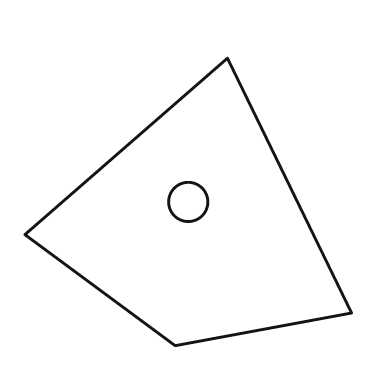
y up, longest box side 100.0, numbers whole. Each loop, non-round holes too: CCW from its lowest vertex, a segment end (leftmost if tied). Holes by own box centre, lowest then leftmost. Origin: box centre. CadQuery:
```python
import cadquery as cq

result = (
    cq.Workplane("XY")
    .moveTo(-4.0, -44.0)
    .lineTo(50.0, -34.0)
    .lineTo(12.0, 44.0)
    .lineTo(-50.0, -10.0)
    .close()
    .moveTo(0.0, 0.0)
    .circle(6.0)
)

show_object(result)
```